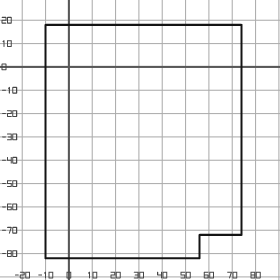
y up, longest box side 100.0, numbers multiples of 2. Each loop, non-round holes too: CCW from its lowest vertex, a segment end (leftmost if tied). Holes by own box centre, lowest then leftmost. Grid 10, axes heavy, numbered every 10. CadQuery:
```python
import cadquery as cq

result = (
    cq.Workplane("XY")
    .moveTo(-10.0, -82.0)
    .lineTo(56.0, -82.0)
    .lineTo(56.0, -72.0)
    .lineTo(74.0, -72.0)
    .lineTo(74.0, 18.0)
    .lineTo(-10.0, 18.0)
    .close()
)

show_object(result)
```